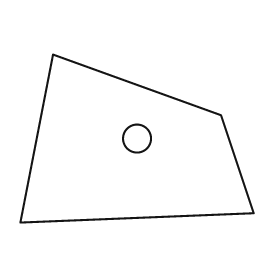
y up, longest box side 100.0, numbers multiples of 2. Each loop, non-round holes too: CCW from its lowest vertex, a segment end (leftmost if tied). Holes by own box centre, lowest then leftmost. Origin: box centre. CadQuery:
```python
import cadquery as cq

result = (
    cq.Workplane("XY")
    .moveTo(-50.0, -36.0)
    .lineTo(50.0, -32.0)
    .lineTo(36.0, 10.0)
    .lineTo(-36.0, 36.0)
    .close()
    .moveTo(0.0, 0.0)
    .circle(6.0)
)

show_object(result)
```